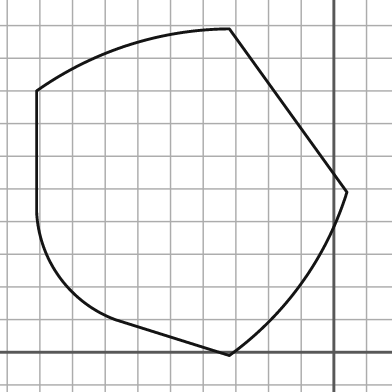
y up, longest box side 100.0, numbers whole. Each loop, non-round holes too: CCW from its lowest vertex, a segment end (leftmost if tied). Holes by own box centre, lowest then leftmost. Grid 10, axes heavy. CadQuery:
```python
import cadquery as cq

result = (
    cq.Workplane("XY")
    .moveTo(-32.0, -1.0)
    .threePointArc((-10.0, 21.0), (4.0, 49.0))
    .lineTo(-32.0, 99.0)
    .threePointArc((-63.0, 94.0), (-91.0, 80.0))
    .lineTo(-91.0, 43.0)
    .threePointArc((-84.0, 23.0), (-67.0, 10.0))
    .close()
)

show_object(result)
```